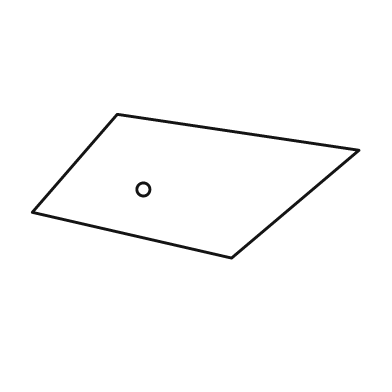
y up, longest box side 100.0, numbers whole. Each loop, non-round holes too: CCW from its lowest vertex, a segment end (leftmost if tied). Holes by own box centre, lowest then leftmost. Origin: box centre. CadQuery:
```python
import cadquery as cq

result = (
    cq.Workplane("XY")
    .moveTo(11.0, -22.0)
    .lineTo(50.0, 11.0)
    .lineTo(-24.0, 22.0)
    .lineTo(-50.0, -8.0)
    .close()
    .moveTo(-16.0, -1.0)
    .circle(2.0)
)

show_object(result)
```